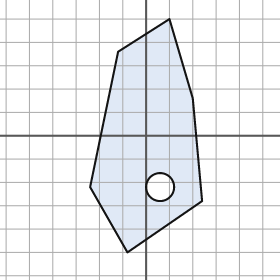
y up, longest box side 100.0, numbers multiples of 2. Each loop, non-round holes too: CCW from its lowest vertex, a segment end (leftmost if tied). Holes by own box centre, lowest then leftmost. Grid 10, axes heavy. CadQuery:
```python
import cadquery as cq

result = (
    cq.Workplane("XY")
    .moveTo(-8.0, -50.0)
    .lineTo(24.0, -28.0)
    .lineTo(20.0, 16.0)
    .lineTo(10.0, 50.0)
    .lineTo(-12.0, 36.0)
    .lineTo(-24.0, -22.0)
    .close()
    .moveTo(6.0, -22.0)
    .circle(6.0)
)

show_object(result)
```